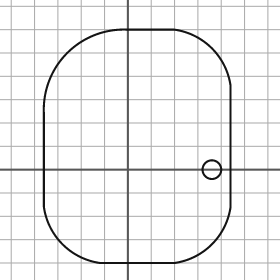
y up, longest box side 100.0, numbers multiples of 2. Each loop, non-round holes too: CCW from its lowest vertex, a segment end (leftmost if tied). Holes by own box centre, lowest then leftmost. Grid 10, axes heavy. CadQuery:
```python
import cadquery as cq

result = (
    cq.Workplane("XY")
    .moveTo(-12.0, -40.0)
    .lineTo(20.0, -40.0)
    .threePointArc((36.0, -32.0), (44.0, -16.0))
    .lineTo(44.0, 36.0)
    .threePointArc((36.0, 52.0), (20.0, 60.0))
    .lineTo(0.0, 60.0)
    .threePointArc((-26.0, 50.0), (-36.0, 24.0))
    .lineTo(-36.0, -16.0)
    .threePointArc((-28.0, -32.0), (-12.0, -40.0))
    .close()
    .moveTo(36.0, 0.0)
    .circle(4.0)
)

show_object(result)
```